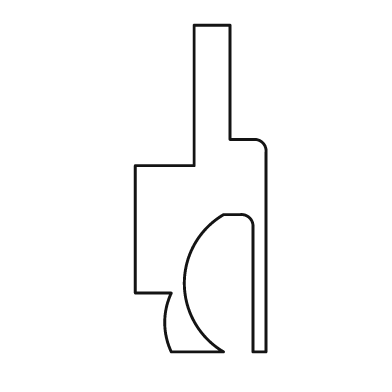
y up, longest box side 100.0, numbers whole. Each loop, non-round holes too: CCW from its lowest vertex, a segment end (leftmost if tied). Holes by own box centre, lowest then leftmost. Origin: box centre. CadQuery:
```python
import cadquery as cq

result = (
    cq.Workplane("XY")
    .moveTo(-9.0, -50.0)
    .lineTo(7.0, -50.0)
    .threePointArc((-5.0, -29.0), (7.0, -8.0))
    .lineTo(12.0, -8.0)
    .threePointArc((15.0, -9.0), (16.0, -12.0))
    .lineTo(16.0, -50.0)
    .lineTo(20.0, -50.0)
    .lineTo(20.0, 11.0)
    .threePointArc((19.0, 14.0), (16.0, 15.0))
    .lineTo(9.0, 15.0)
    .lineTo(9.0, 50.0)
    .lineTo(-2.0, 50.0)
    .lineTo(-2.0, 7.0)
    .lineTo(-20.0, 7.0)
    .lineTo(-20.0, -32.0)
    .lineTo(-9.0, -32.0)
    .threePointArc((-11.0, -41.0), (-9.0, -50.0))
    .close()
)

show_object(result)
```